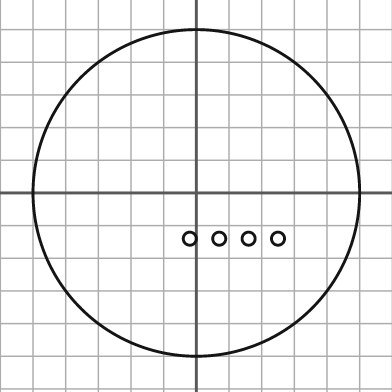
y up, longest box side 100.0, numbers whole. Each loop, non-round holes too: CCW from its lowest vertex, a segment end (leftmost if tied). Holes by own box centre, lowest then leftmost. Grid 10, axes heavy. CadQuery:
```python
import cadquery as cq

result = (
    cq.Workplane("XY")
    .moveTo(0.0, 0.0)
    .circle(50.0)
    .moveTo(-2.0, -14.0)
    .circle(2.0)
    .moveTo(7.0, -14.0)
    .circle(2.0)
    .moveTo(16.0, -14.0)
    .circle(2.0)
    .moveTo(25.0, -14.0)
    .circle(2.0)
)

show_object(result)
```